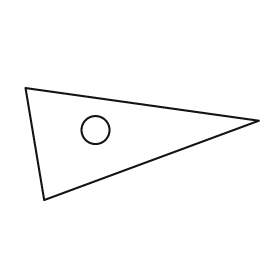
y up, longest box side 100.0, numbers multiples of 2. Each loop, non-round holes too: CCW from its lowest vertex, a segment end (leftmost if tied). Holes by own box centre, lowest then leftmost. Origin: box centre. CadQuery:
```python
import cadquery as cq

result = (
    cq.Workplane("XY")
    .moveTo(-42.0, -24.0)
    .lineTo(50.0, 10.0)
    .lineTo(-50.0, 24.0)
    .close()
    .moveTo(-20.0, 6.0)
    .circle(6.0)
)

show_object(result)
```